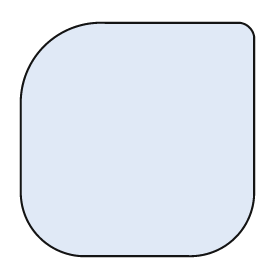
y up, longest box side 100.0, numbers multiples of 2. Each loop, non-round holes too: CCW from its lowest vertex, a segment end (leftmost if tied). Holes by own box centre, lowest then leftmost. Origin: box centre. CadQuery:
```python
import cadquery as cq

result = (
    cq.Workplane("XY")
    .moveTo(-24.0, -50.0)
    .lineTo(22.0, -50.0)
    .threePointArc((42.0, -42.0), (50.0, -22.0))
    .lineTo(50.0, 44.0)
    .threePointArc((48.0, 48.0), (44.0, 50.0))
    .lineTo(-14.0, 50.0)
    .threePointArc((-40.0, 40.0), (-50.0, 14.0))
    .lineTo(-50.0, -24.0)
    .threePointArc((-42.0, -42.0), (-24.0, -50.0))
    .close()
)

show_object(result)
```